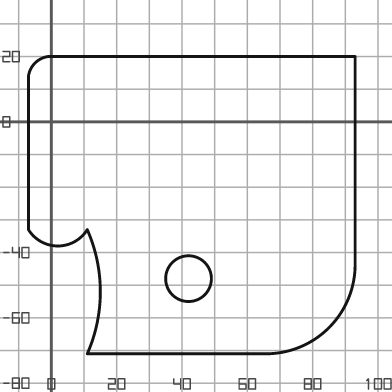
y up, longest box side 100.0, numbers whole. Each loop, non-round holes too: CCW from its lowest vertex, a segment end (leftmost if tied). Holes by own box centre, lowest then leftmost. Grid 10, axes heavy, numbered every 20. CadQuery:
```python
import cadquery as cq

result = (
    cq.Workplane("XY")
    .moveTo(11.0, -71.0)
    .lineTo(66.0, -71.0)
    .threePointArc((85.0, -63.0), (93.0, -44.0))
    .lineTo(93.0, 20.0)
    .lineTo(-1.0, 20.0)
    .threePointArc((-5.0, 18.0), (-7.0, 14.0))
    .lineTo(-7.0, -33.0)
    .threePointArc((2.0, -38.0), (11.0, -33.0))
    .threePointArc((15.0, -52.0), (11.0, -71.0))
    .close()
    .moveTo(42.0, -48.0)
    .circle(7.0)
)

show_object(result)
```